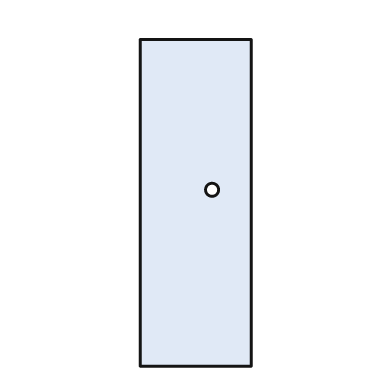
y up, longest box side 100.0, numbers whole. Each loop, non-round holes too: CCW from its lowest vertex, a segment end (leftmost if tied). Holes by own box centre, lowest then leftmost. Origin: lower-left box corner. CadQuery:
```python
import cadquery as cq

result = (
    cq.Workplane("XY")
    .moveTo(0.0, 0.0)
    .lineTo(34.0, 0.0)
    .lineTo(34.0, 100.0)
    .lineTo(0.0, 100.0)
    .close()
    .moveTo(22.0, 54.0)
    .circle(2.0)
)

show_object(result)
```